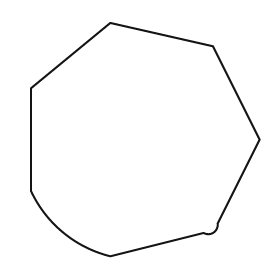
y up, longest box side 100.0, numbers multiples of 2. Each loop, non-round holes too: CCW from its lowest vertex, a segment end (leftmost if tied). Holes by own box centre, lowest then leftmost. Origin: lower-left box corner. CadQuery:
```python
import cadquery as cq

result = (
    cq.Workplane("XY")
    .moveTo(34.0, 0.0)
    .lineTo(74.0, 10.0)
    .threePointArc((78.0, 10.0), (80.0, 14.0))
    .lineTo(98.0, 50.0)
    .lineTo(78.0, 90.0)
    .lineTo(34.0, 100.0)
    .lineTo(0.0, 72.0)
    .lineTo(0.0, 28.0)
    .threePointArc((14.0, 10.0), (34.0, 0.0))
    .close()
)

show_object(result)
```